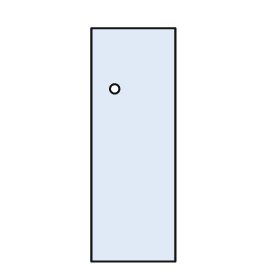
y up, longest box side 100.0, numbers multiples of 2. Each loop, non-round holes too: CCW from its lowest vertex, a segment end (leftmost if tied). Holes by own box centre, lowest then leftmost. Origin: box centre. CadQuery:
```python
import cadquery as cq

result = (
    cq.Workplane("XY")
    .moveTo(-18.0, -50.0)
    .lineTo(18.0, -50.0)
    .lineTo(18.0, 50.0)
    .lineTo(-18.0, 50.0)
    .close()
    .moveTo(-8.0, 24.0)
    .circle(2.0)
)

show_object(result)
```